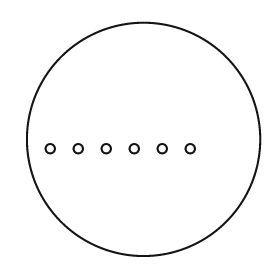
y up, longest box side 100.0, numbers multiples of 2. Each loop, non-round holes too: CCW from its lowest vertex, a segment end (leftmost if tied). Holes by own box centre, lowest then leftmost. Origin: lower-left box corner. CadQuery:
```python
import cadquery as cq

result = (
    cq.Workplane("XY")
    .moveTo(50.0, 50.0)
    .circle(50.0)
    .moveTo(10.0, 46.0)
    .circle(2.0)
    .moveTo(22.0, 46.0)
    .circle(2.0)
    .moveTo(34.0, 46.0)
    .circle(2.0)
    .moveTo(46.0, 46.0)
    .circle(2.0)
    .moveTo(58.0, 46.0)
    .circle(2.0)
    .moveTo(70.0, 46.0)
    .circle(2.0)
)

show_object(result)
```